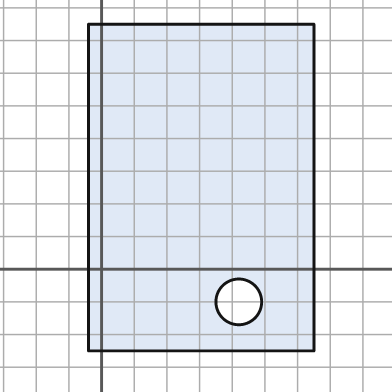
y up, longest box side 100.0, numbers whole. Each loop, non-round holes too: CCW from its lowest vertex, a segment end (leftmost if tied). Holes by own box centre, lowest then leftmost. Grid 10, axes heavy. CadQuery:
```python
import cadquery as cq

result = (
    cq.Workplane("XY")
    .moveTo(-4.0, -25.0)
    .lineTo(65.0, -25.0)
    .lineTo(65.0, 75.0)
    .lineTo(-4.0, 75.0)
    .close()
    .moveTo(42.0, -10.0)
    .circle(7.0)
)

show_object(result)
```